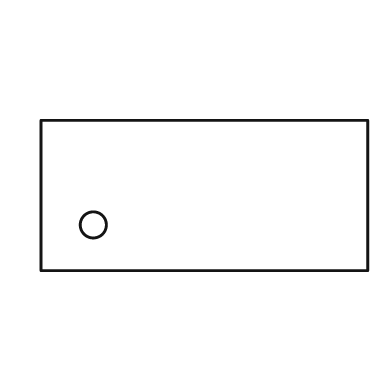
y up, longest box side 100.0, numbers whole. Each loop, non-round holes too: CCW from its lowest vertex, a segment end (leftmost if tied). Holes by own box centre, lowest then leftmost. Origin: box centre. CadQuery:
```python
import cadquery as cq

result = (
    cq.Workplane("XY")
    .moveTo(-50.0, -23.0)
    .lineTo(50.0, -23.0)
    .lineTo(50.0, 23.0)
    .lineTo(-50.0, 23.0)
    .close()
    .moveTo(-34.0, -9.0)
    .circle(4.0)
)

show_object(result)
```